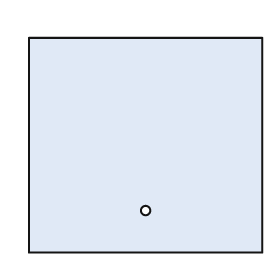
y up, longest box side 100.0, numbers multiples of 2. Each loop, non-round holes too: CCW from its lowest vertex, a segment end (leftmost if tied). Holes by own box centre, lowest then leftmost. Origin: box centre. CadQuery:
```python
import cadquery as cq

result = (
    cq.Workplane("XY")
    .moveTo(-50.0, -46.0)
    .lineTo(50.0, -46.0)
    .lineTo(50.0, 46.0)
    .lineTo(-50.0, 46.0)
    .close()
    .moveTo(0.0, -28.0)
    .circle(2.0)
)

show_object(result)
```